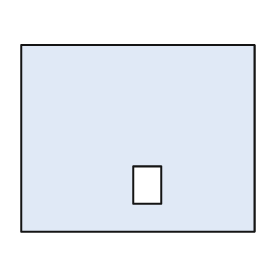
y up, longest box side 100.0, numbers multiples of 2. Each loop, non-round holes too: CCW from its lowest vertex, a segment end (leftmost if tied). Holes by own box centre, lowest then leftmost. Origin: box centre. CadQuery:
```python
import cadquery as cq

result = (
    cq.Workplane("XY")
    .moveTo(-50.0, -40.0)
    .lineTo(50.0, -40.0)
    .lineTo(50.0, 40.0)
    .lineTo(-50.0, 40.0)
    .close()
    .moveTo(-2.0, -28.0)
    .lineTo(10.0, -28.0)
    .lineTo(10.0, -12.0)
    .lineTo(-2.0, -12.0)
    .close()
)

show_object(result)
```